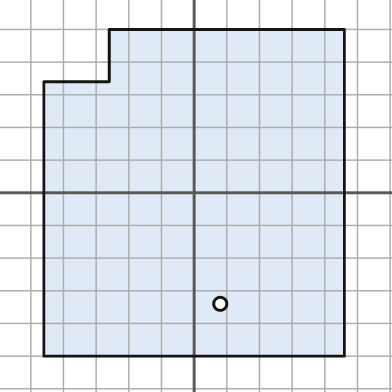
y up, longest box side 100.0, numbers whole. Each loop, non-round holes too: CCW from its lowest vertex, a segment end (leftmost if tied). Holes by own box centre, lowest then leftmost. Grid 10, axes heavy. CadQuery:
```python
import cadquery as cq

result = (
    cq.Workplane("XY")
    .moveTo(-46.0, -50.0)
    .lineTo(46.0, -50.0)
    .lineTo(46.0, 50.0)
    .lineTo(-26.0, 50.0)
    .lineTo(-26.0, 34.0)
    .lineTo(-46.0, 34.0)
    .close()
    .moveTo(8.0, -34.0)
    .circle(2.0)
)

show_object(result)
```